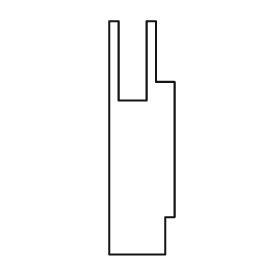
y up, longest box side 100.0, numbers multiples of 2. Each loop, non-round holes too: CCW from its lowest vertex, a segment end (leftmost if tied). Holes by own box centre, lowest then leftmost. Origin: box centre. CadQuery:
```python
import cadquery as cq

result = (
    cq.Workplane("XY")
    .moveTo(-14.0, -50.0)
    .lineTo(10.0, -50.0)
    .lineTo(10.0, -34.0)
    .lineTo(14.0, -34.0)
    .lineTo(14.0, 24.0)
    .lineTo(6.0, 24.0)
    .lineTo(6.0, 50.0)
    .lineTo(2.0, 50.0)
    .lineTo(2.0, 16.0)
    .lineTo(-10.0, 16.0)
    .lineTo(-10.0, 50.0)
    .lineTo(-14.0, 50.0)
    .close()
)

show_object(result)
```